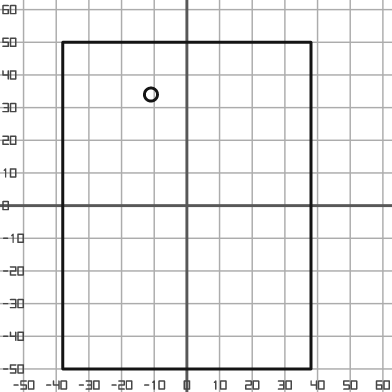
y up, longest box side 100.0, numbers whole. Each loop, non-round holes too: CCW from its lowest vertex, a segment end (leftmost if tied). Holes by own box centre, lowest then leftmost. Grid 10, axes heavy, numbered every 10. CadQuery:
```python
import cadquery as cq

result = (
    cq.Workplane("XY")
    .moveTo(-38.0, -50.0)
    .lineTo(38.0, -50.0)
    .lineTo(38.0, 50.0)
    .lineTo(-38.0, 50.0)
    .close()
    .moveTo(-11.0, 34.0)
    .circle(2.0)
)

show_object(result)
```